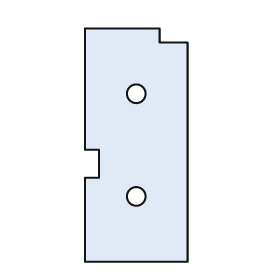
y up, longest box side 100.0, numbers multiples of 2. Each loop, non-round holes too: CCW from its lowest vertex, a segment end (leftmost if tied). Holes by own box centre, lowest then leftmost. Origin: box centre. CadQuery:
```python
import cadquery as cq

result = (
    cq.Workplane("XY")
    .moveTo(-22.0, -50.0)
    .lineTo(22.0, -50.0)
    .lineTo(22.0, 44.0)
    .lineTo(10.0, 44.0)
    .lineTo(10.0, 50.0)
    .lineTo(-22.0, 50.0)
    .lineTo(-22.0, -2.0)
    .lineTo(-16.0, -2.0)
    .lineTo(-16.0, -14.0)
    .lineTo(-22.0, -14.0)
    .close()
    .moveTo(0.0, -22.0)
    .circle(4.0)
    .moveTo(0.0, 22.0)
    .circle(4.0)
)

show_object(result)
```